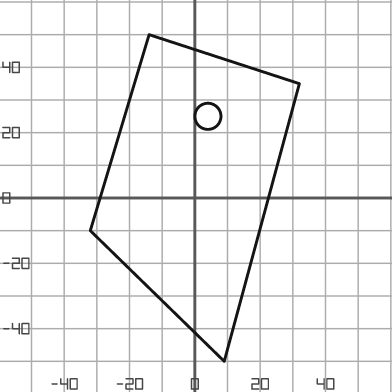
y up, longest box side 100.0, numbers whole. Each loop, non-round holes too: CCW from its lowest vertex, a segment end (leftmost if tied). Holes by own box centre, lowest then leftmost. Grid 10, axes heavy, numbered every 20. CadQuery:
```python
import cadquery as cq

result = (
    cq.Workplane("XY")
    .moveTo(9.0, -50.0)
    .lineTo(32.0, 35.0)
    .lineTo(-14.0, 50.0)
    .lineTo(-32.0, -10.0)
    .close()
    .moveTo(4.0, 25.0)
    .circle(4.0)
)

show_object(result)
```